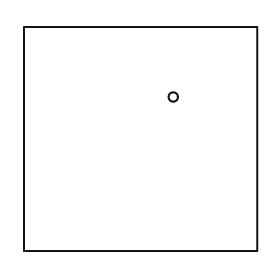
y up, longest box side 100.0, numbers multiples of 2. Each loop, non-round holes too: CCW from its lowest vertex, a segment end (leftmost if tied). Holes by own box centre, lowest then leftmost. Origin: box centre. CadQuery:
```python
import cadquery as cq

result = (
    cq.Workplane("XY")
    .moveTo(-50.0, -48.0)
    .lineTo(50.0, -48.0)
    .lineTo(50.0, 48.0)
    .lineTo(-50.0, 48.0)
    .close()
    .moveTo(14.0, 18.0)
    .circle(2.0)
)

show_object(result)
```